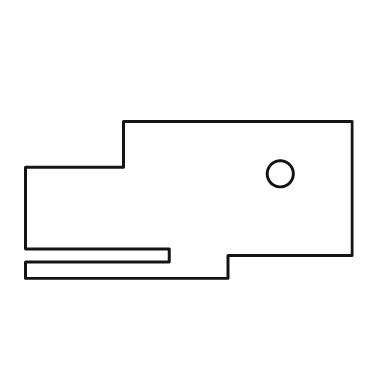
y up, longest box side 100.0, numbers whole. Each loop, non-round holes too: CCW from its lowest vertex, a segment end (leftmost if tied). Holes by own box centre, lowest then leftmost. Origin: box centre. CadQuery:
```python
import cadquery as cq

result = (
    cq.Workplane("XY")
    .moveTo(-50.0, -24.0)
    .lineTo(12.0, -24.0)
    .lineTo(12.0, -17.0)
    .lineTo(50.0, -17.0)
    .lineTo(50.0, 24.0)
    .lineTo(-20.0, 24.0)
    .lineTo(-20.0, 10.0)
    .lineTo(-50.0, 10.0)
    .lineTo(-50.0, -15.0)
    .lineTo(-6.0, -15.0)
    .lineTo(-6.0, -19.0)
    .lineTo(-50.0, -19.0)
    .close()
    .moveTo(28.0, 8.0)
    .circle(4.0)
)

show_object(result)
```